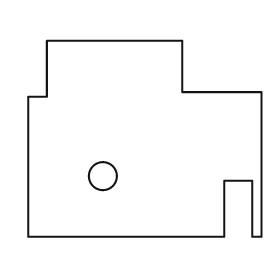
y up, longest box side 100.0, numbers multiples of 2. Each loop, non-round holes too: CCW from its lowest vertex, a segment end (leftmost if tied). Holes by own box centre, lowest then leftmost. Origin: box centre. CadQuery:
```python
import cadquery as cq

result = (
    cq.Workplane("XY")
    .moveTo(-50.0, -42.0)
    .lineTo(34.0, -42.0)
    .lineTo(34.0, -18.0)
    .lineTo(46.0, -18.0)
    .lineTo(46.0, -42.0)
    .lineTo(50.0, -42.0)
    .lineTo(50.0, 20.0)
    .lineTo(16.0, 20.0)
    .lineTo(16.0, 42.0)
    .lineTo(-42.0, 42.0)
    .lineTo(-42.0, 18.0)
    .lineTo(-50.0, 18.0)
    .close()
    .moveTo(-18.0, -16.0)
    .circle(6.0)
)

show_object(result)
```